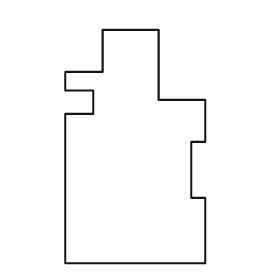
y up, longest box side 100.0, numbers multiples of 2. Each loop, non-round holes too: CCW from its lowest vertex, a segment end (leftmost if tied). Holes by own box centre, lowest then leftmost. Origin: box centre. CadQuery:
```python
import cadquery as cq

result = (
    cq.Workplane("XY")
    .moveTo(-30.0, -50.0)
    .lineTo(30.0, -50.0)
    .lineTo(30.0, -22.0)
    .lineTo(24.0, -22.0)
    .lineTo(24.0, 2.0)
    .lineTo(30.0, 2.0)
    .lineTo(30.0, 20.0)
    .lineTo(10.0, 20.0)
    .lineTo(10.0, 50.0)
    .lineTo(-14.0, 50.0)
    .lineTo(-14.0, 32.0)
    .lineTo(-30.0, 32.0)
    .lineTo(-30.0, 24.0)
    .lineTo(-18.0, 24.0)
    .lineTo(-18.0, 14.0)
    .lineTo(-30.0, 14.0)
    .close()
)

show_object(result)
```